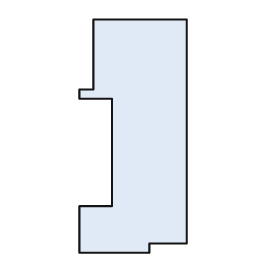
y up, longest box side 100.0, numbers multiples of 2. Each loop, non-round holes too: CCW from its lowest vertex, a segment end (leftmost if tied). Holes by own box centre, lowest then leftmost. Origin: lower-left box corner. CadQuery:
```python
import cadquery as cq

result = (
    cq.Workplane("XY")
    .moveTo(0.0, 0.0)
    .lineTo(30.0, 0.0)
    .lineTo(30.0, 4.0)
    .lineTo(46.0, 4.0)
    .lineTo(46.0, 100.0)
    .lineTo(6.0, 100.0)
    .lineTo(6.0, 70.0)
    .lineTo(0.0, 70.0)
    .lineTo(0.0, 66.0)
    .lineTo(14.0, 66.0)
    .lineTo(14.0, 20.0)
    .lineTo(0.0, 20.0)
    .close()
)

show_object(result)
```